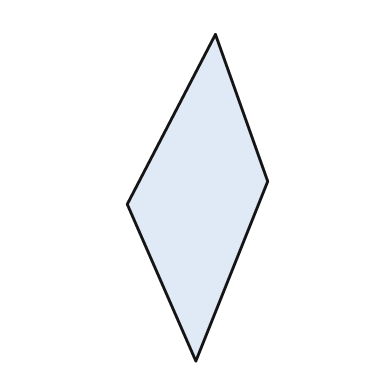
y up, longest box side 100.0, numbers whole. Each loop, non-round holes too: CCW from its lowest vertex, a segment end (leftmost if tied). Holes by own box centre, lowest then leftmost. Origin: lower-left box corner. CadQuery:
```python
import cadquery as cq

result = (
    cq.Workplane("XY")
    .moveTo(21.0, 0.0)
    .lineTo(43.0, 55.0)
    .lineTo(27.0, 100.0)
    .lineTo(0.0, 48.0)
    .close()
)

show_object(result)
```